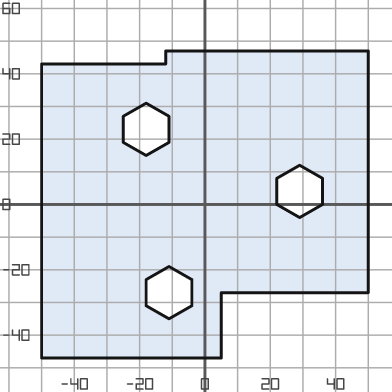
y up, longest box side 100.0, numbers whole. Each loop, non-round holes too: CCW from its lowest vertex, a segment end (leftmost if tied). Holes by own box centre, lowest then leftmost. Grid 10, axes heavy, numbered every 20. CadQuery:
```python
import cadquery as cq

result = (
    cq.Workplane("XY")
    .moveTo(-50.0, -47.0)
    .lineTo(5.0, -47.0)
    .lineTo(5.0, -27.0)
    .lineTo(50.0, -27.0)
    .lineTo(50.0, 47.0)
    .lineTo(-12.0, 47.0)
    .lineTo(-12.0, 43.0)
    .lineTo(-50.0, 43.0)
    .close()
    .moveTo(-11.0, -35.0)
    .lineTo(-4.0, -31.0)
    .lineTo(-4.0, -23.0)
    .lineTo(-11.0, -19.0)
    .lineTo(-18.0, -23.0)
    .lineTo(-18.0, -31.0)
    .close()
    .moveTo(29.0, -4.0)
    .lineTo(36.0, 0.0)
    .lineTo(36.0, 8.0)
    .lineTo(29.0, 12.0)
    .lineTo(22.0, 8.0)
    .lineTo(22.0, 0.0)
    .close()
    .moveTo(-18.0, 15.0)
    .lineTo(-11.0, 19.0)
    .lineTo(-11.0, 27.0)
    .lineTo(-18.0, 31.0)
    .lineTo(-25.0, 27.0)
    .lineTo(-25.0, 19.0)
    .close()
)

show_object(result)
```